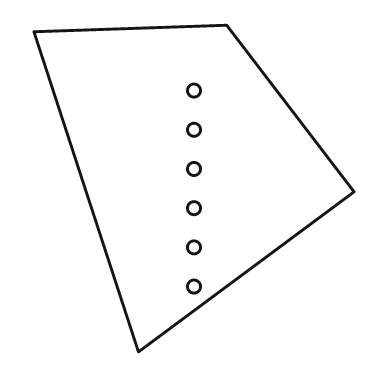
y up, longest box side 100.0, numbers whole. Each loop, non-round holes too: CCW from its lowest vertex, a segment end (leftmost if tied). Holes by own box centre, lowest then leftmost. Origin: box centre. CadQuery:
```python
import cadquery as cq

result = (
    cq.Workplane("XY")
    .moveTo(-17.0, -50.0)
    .lineTo(49.0, -1.0)
    .lineTo(10.0, 50.0)
    .lineTo(-49.0, 48.0)
    .close()
    .moveTo(0.0, -30.0)
    .circle(2.0)
    .moveTo(0.0, -18.0)
    .circle(2.0)
    .moveTo(0.0, -6.0)
    .circle(2.0)
    .moveTo(0.0, 6.0)
    .circle(2.0)
    .moveTo(0.0, 18.0)
    .circle(2.0)
    .moveTo(0.0, 30.0)
    .circle(2.0)
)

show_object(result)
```